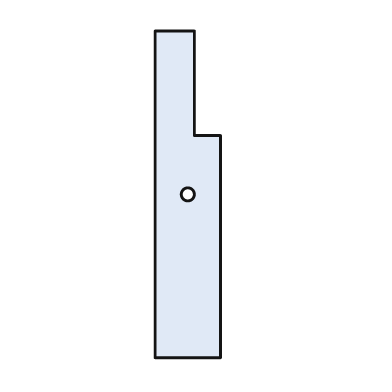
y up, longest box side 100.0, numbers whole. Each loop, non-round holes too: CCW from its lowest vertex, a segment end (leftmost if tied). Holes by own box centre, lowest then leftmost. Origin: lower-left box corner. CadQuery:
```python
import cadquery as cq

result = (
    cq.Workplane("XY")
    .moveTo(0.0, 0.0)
    .lineTo(20.0, 0.0)
    .lineTo(20.0, 68.0)
    .lineTo(12.0, 68.0)
    .lineTo(12.0, 100.0)
    .lineTo(0.0, 100.0)
    .close()
    .moveTo(10.0, 50.0)
    .circle(2.0)
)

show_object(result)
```